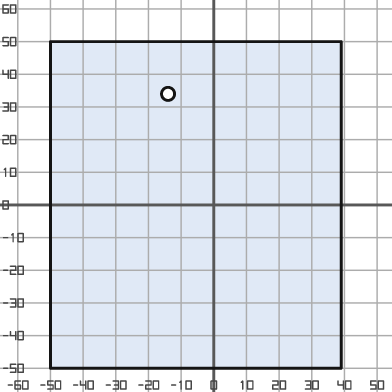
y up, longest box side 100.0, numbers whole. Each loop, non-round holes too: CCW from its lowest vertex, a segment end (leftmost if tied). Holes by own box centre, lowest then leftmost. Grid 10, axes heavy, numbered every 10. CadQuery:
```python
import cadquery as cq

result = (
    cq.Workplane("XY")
    .moveTo(-50.0, -50.0)
    .lineTo(39.0, -50.0)
    .lineTo(39.0, 50.0)
    .lineTo(-50.0, 50.0)
    .close()
    .moveTo(-14.0, 34.0)
    .circle(2.0)
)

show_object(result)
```